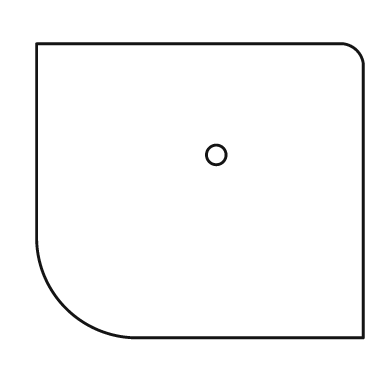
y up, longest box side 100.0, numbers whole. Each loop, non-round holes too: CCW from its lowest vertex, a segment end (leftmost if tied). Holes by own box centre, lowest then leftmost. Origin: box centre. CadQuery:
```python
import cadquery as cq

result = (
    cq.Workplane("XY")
    .moveTo(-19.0, -45.0)
    .lineTo(50.0, -45.0)
    .lineTo(50.0, 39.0)
    .threePointArc((48.0, 43.0), (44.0, 45.0))
    .lineTo(-50.0, 45.0)
    .lineTo(-50.0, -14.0)
    .threePointArc((-41.0, -36.0), (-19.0, -45.0))
    .close()
    .moveTo(5.0, 11.0)
    .circle(3.0)
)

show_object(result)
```